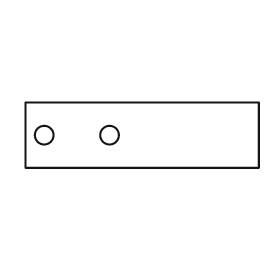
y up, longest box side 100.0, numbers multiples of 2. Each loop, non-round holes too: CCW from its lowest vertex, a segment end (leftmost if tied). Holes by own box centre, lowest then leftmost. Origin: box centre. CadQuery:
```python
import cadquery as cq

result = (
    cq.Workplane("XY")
    .moveTo(-50.0, -14.0)
    .lineTo(50.0, -14.0)
    .lineTo(50.0, 14.0)
    .lineTo(-50.0, 14.0)
    .close()
    .moveTo(-42.0, 0.0)
    .circle(4.0)
    .moveTo(-14.0, 0.0)
    .circle(4.0)
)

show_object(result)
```